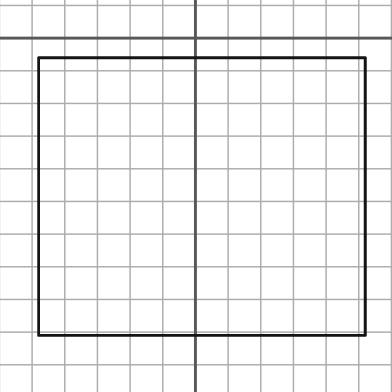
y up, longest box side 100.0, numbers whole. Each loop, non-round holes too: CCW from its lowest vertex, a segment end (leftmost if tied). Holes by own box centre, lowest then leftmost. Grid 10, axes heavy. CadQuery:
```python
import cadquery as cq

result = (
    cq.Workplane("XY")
    .moveTo(-48.0, -91.0)
    .lineTo(52.0, -91.0)
    .lineTo(52.0, -6.0)
    .lineTo(-48.0, -6.0)
    .close()
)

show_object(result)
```